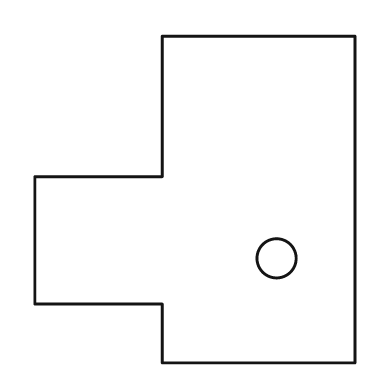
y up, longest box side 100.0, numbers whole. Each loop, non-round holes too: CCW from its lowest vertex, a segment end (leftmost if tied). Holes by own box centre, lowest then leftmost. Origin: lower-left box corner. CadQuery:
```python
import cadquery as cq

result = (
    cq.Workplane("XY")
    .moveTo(39.0, 0.0)
    .lineTo(98.0, 0.0)
    .lineTo(98.0, 100.0)
    .lineTo(39.0, 100.0)
    .lineTo(39.0, 57.0)
    .lineTo(0.0, 57.0)
    .lineTo(0.0, 18.0)
    .lineTo(39.0, 18.0)
    .close()
    .moveTo(74.0, 32.0)
    .circle(6.0)
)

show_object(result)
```